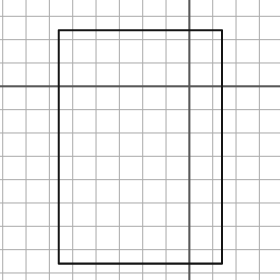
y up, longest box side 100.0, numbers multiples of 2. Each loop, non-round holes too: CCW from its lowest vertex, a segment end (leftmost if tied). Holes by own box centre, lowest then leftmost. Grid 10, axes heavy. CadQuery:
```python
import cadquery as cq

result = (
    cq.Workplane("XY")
    .moveTo(-56.0, -76.0)
    .lineTo(14.0, -76.0)
    .lineTo(14.0, 24.0)
    .lineTo(-56.0, 24.0)
    .close()
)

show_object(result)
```